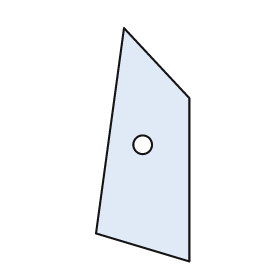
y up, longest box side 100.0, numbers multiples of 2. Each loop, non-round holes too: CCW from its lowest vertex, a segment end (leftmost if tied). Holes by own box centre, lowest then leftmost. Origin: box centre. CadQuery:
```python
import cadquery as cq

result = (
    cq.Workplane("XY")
    .moveTo(20.0, -50.0)
    .lineTo(20.0, 20.0)
    .lineTo(-8.0, 50.0)
    .lineTo(-20.0, -38.0)
    .close()
    .moveTo(0.0, 0.0)
    .circle(4.0)
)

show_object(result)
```